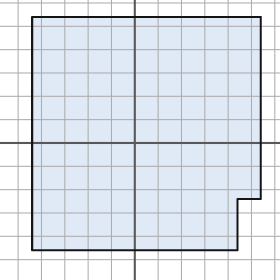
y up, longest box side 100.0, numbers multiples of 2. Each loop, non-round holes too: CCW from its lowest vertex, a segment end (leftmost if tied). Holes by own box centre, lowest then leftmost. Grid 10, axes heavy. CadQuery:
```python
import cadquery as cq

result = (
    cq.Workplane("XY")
    .moveTo(-44.0, -46.0)
    .lineTo(44.0, -46.0)
    .lineTo(44.0, -24.0)
    .lineTo(54.0, -24.0)
    .lineTo(54.0, 54.0)
    .lineTo(-44.0, 54.0)
    .close()
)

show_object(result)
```